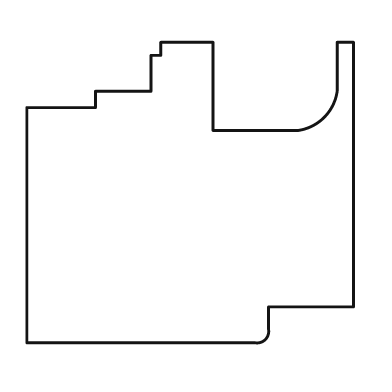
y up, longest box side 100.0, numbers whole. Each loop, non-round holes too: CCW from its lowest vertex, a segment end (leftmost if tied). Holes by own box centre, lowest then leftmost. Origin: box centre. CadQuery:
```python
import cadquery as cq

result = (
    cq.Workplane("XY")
    .moveTo(-50.0, -46.0)
    .lineTo(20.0, -46.0)
    .threePointArc((23.0, -45.0), (24.0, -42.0))
    .lineTo(24.0, -35.0)
    .lineTo(50.0, -35.0)
    .lineTo(50.0, 46.0)
    .lineTo(45.0, 46.0)
    .lineTo(45.0, 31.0)
    .threePointArc((41.0, 23.0), (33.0, 19.0))
    .lineTo(7.0, 19.0)
    .lineTo(7.0, 46.0)
    .lineTo(-9.0, 46.0)
    .lineTo(-9.0, 42.0)
    .lineTo(-12.0, 42.0)
    .lineTo(-12.0, 31.0)
    .lineTo(-29.0, 31.0)
    .lineTo(-29.0, 26.0)
    .lineTo(-50.0, 26.0)
    .close()
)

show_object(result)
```